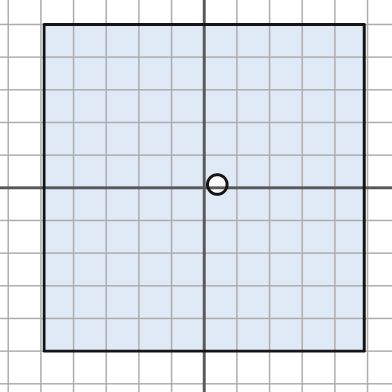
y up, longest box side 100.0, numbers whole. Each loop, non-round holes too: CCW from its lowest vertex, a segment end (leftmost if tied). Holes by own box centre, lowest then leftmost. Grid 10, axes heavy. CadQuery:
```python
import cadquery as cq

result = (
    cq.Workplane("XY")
    .moveTo(-49.0, -50.0)
    .lineTo(49.0, -50.0)
    .lineTo(49.0, 50.0)
    .lineTo(-49.0, 50.0)
    .close()
    .moveTo(4.0, 1.0)
    .circle(3.0)
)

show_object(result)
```